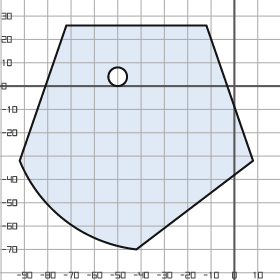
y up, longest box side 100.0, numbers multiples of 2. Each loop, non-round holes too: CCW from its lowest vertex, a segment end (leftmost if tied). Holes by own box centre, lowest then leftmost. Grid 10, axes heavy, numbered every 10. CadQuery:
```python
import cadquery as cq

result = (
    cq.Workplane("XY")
    .moveTo(-42.0, -70.0)
    .lineTo(8.0, -32.0)
    .lineTo(-12.0, 26.0)
    .lineTo(-72.0, 26.0)
    .lineTo(-92.0, -32.0)
    .threePointArc((-72.0, -58.0), (-42.0, -70.0))
    .close()
    .moveTo(-50.0, 4.0)
    .circle(4.0)
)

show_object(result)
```